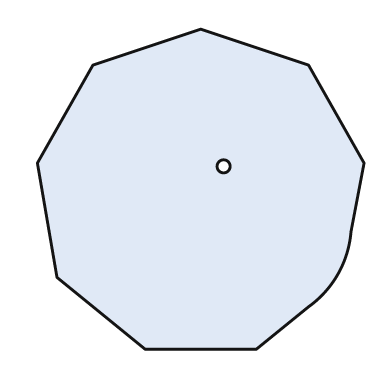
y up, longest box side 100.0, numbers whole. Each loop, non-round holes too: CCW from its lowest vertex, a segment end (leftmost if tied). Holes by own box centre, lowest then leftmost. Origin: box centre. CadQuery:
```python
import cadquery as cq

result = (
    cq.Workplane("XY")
    .moveTo(-17.0, -49.0)
    .lineTo(17.0, -49.0)
    .lineTo(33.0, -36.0)
    .threePointArc((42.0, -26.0), (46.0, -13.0))
    .lineTo(50.0, 8.0)
    .lineTo(33.0, 38.0)
    .lineTo(0.0, 49.0)
    .lineTo(-33.0, 38.0)
    .lineTo(-50.0, 8.0)
    .lineTo(-44.0, -27.0)
    .close()
    .moveTo(7.0, 7.0)
    .circle(2.0)
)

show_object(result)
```